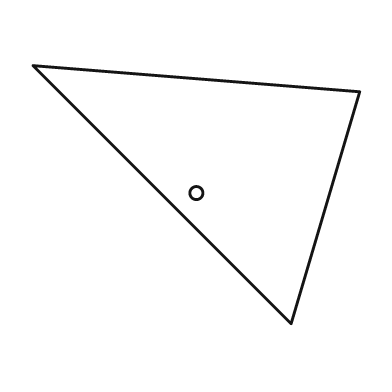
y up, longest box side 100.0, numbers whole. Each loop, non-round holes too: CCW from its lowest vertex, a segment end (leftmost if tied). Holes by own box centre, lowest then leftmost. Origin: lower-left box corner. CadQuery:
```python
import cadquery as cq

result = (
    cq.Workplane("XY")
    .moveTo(79.0, 0.0)
    .lineTo(100.0, 71.0)
    .lineTo(0.0, 79.0)
    .close()
    .moveTo(50.0, 40.0)
    .circle(2.0)
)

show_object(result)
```